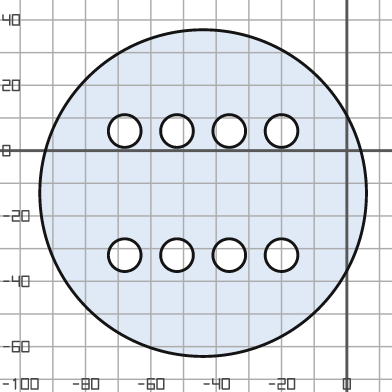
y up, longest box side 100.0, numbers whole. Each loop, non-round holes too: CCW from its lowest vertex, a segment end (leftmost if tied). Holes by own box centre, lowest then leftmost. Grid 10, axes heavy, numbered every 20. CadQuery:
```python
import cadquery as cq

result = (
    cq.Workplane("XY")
    .moveTo(-44.0, -13.0)
    .circle(50.0)
    .moveTo(-68.0, -32.0)
    .circle(5.0)
    .moveTo(-52.0, -32.0)
    .circle(5.0)
    .moveTo(-36.0, -32.0)
    .circle(5.0)
    .moveTo(-20.0, -32.0)
    .circle(5.0)
    .moveTo(-68.0, 6.0)
    .circle(5.0)
    .moveTo(-52.0, 6.0)
    .circle(5.0)
    .moveTo(-36.0, 6.0)
    .circle(5.0)
    .moveTo(-20.0, 6.0)
    .circle(5.0)
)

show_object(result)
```